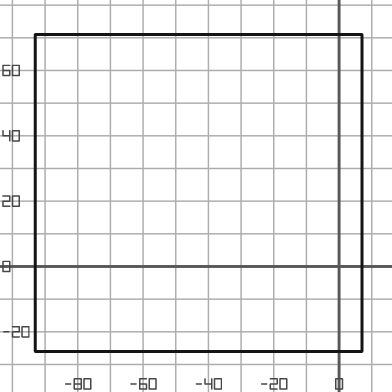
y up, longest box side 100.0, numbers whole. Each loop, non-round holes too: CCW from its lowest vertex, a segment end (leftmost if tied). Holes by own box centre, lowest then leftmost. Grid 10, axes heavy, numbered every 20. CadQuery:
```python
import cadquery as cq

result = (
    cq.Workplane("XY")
    .moveTo(-93.0, -26.0)
    .lineTo(7.0, -26.0)
    .lineTo(7.0, 71.0)
    .lineTo(-93.0, 71.0)
    .close()
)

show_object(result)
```